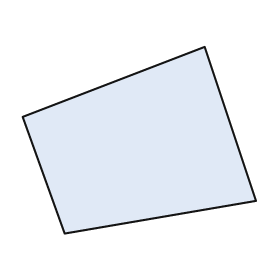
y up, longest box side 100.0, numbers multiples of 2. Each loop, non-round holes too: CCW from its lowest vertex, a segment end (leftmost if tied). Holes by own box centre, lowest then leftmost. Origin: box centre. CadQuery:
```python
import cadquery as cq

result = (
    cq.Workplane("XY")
    .moveTo(-32.0, -40.0)
    .lineTo(50.0, -26.0)
    .lineTo(28.0, 40.0)
    .lineTo(-50.0, 10.0)
    .close()
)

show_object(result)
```